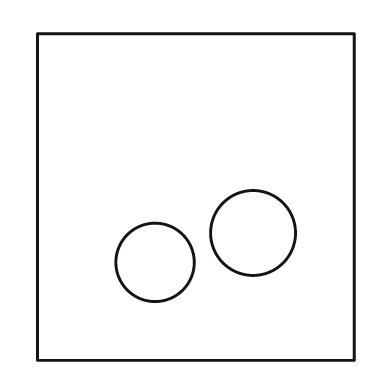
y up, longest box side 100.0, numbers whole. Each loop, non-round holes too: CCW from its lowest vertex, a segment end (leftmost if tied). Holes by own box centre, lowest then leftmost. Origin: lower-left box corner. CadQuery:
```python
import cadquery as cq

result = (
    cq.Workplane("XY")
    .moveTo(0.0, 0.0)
    .lineTo(97.0, 0.0)
    .lineTo(97.0, 100.0)
    .lineTo(0.0, 100.0)
    .close()
    .moveTo(36.0, 30.0)
    .circle(12.0)
    .moveTo(66.0, 39.0)
    .circle(13.0)
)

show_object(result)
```